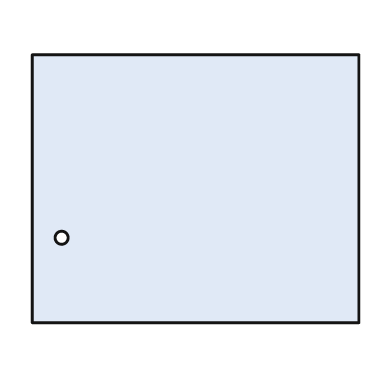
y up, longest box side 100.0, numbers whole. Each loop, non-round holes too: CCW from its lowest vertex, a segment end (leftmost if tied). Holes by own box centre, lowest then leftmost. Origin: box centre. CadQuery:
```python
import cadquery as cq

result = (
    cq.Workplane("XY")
    .moveTo(-50.0, -41.0)
    .lineTo(50.0, -41.0)
    .lineTo(50.0, 41.0)
    .lineTo(-50.0, 41.0)
    .close()
    .moveTo(-41.0, -15.0)
    .circle(2.0)
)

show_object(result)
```